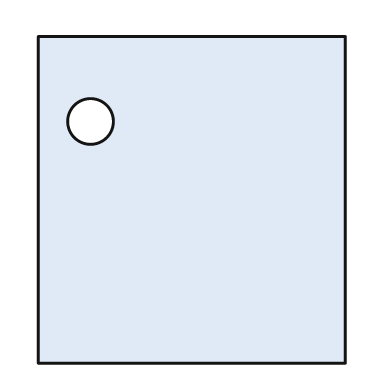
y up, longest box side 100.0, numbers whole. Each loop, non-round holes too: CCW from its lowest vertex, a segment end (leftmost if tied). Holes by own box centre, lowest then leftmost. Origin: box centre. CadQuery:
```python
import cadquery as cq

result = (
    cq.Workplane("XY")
    .moveTo(-47.0, -50.0)
    .lineTo(47.0, -50.0)
    .lineTo(47.0, 50.0)
    .lineTo(-47.0, 50.0)
    .close()
    .moveTo(-31.0, 24.0)
    .circle(7.0)
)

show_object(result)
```